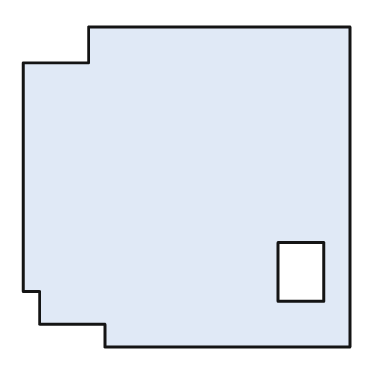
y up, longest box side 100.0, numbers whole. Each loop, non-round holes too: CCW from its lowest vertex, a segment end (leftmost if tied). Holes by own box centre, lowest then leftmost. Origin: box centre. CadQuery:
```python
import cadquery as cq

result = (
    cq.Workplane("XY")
    .moveTo(-25.0, -49.0)
    .lineTo(50.0, -49.0)
    .lineTo(50.0, 49.0)
    .lineTo(-30.0, 49.0)
    .lineTo(-30.0, 38.0)
    .lineTo(-50.0, 38.0)
    .lineTo(-50.0, -32.0)
    .lineTo(-45.0, -32.0)
    .lineTo(-45.0, -42.0)
    .lineTo(-25.0, -42.0)
    .close()
    .moveTo(28.0, -35.0)
    .lineTo(42.0, -35.0)
    .lineTo(42.0, -17.0)
    .lineTo(28.0, -17.0)
    .close()
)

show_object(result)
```